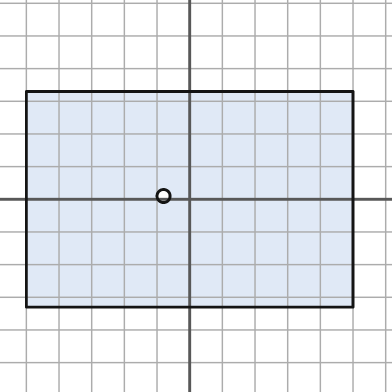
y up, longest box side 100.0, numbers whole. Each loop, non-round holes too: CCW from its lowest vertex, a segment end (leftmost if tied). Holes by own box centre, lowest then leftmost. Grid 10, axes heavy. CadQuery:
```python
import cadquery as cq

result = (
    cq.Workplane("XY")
    .moveTo(-50.0, -33.0)
    .lineTo(50.0, -33.0)
    .lineTo(50.0, 33.0)
    .lineTo(-50.0, 33.0)
    .close()
    .moveTo(-8.0, 1.0)
    .circle(2.0)
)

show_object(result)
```